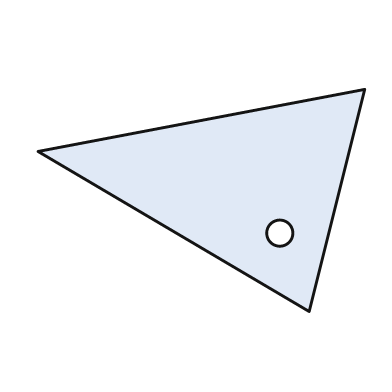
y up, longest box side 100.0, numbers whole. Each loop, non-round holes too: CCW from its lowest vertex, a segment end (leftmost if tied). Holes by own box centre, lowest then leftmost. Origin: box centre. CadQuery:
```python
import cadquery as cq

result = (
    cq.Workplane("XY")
    .moveTo(33.0, -34.0)
    .lineTo(50.0, 34.0)
    .lineTo(-50.0, 15.0)
    .close()
    .moveTo(24.0, -10.0)
    .circle(4.0)
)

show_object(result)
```